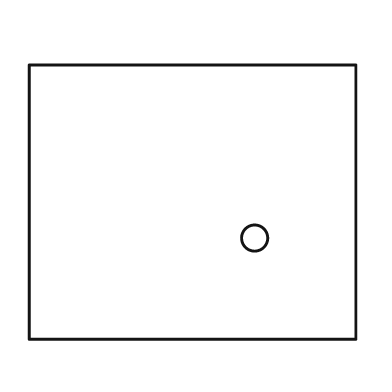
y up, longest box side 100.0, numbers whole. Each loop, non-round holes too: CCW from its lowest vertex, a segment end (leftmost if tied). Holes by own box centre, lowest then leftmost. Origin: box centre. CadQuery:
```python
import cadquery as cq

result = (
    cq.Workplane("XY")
    .moveTo(-50.0, -42.0)
    .lineTo(50.0, -42.0)
    .lineTo(50.0, 42.0)
    .lineTo(-50.0, 42.0)
    .close()
    .moveTo(19.0, -11.0)
    .circle(4.0)
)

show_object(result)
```